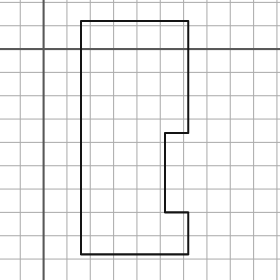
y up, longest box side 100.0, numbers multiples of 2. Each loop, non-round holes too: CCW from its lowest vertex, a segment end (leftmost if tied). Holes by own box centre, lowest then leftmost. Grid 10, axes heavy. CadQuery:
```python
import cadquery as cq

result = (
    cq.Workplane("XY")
    .moveTo(16.0, -88.0)
    .lineTo(62.0, -88.0)
    .lineTo(62.0, -70.0)
    .lineTo(52.0, -70.0)
    .lineTo(52.0, -36.0)
    .lineTo(62.0, -36.0)
    .lineTo(62.0, 12.0)
    .lineTo(16.0, 12.0)
    .close()
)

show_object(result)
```